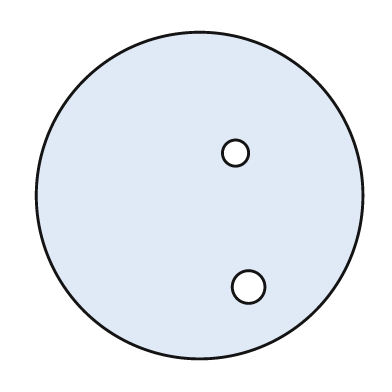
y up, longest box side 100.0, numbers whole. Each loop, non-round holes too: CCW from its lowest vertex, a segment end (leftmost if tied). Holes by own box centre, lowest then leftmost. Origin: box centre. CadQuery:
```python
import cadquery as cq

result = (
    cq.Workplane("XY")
    .moveTo(0.0, 0.0)
    .circle(50.0)
    .moveTo(15.0, -28.0)
    .circle(5.0)
    .moveTo(11.0, 13.0)
    .circle(4.0)
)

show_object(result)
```